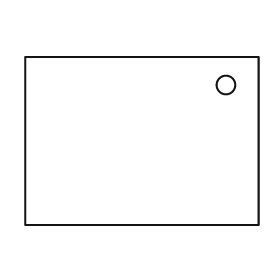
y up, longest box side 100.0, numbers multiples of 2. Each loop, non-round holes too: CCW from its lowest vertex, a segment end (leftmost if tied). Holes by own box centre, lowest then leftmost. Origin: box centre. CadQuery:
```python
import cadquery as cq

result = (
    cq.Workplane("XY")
    .moveTo(-50.0, -36.0)
    .lineTo(50.0, -36.0)
    .lineTo(50.0, 36.0)
    .lineTo(-50.0, 36.0)
    .close()
    .moveTo(36.0, 24.0)
    .circle(4.0)
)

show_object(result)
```